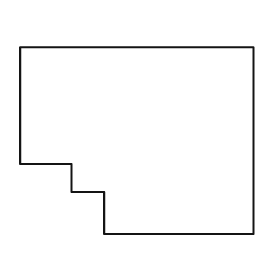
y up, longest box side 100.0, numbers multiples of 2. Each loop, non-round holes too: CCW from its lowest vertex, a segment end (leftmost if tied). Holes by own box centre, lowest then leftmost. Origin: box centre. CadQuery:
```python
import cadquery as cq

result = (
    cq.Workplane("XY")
    .moveTo(-14.0, -40.0)
    .lineTo(50.0, -40.0)
    .lineTo(50.0, 40.0)
    .lineTo(-50.0, 40.0)
    .lineTo(-50.0, -10.0)
    .lineTo(-28.0, -10.0)
    .lineTo(-28.0, -22.0)
    .lineTo(-14.0, -22.0)
    .close()
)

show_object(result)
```